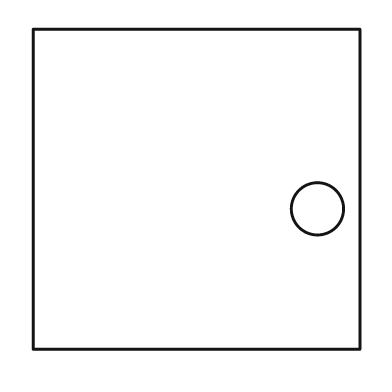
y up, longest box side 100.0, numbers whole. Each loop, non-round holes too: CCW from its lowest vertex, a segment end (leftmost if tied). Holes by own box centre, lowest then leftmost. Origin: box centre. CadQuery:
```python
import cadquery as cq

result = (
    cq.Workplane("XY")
    .moveTo(-50.0, -49.0)
    .lineTo(50.0, -49.0)
    .lineTo(50.0, 49.0)
    .lineTo(-50.0, 49.0)
    .close()
    .moveTo(37.0, -6.0)
    .circle(8.0)
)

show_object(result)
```